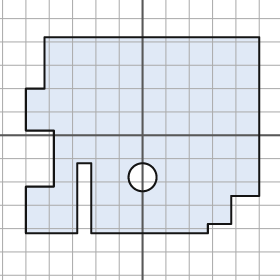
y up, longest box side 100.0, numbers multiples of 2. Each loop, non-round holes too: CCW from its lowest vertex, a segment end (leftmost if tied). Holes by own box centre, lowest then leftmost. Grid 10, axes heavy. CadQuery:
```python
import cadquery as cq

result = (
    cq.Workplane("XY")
    .moveTo(-50.0, -42.0)
    .lineTo(-28.0, -42.0)
    .lineTo(-28.0, -12.0)
    .lineTo(-22.0, -12.0)
    .lineTo(-22.0, -42.0)
    .lineTo(28.0, -42.0)
    .lineTo(28.0, -38.0)
    .lineTo(38.0, -38.0)
    .lineTo(38.0, -26.0)
    .lineTo(50.0, -26.0)
    .lineTo(50.0, 42.0)
    .lineTo(-42.0, 42.0)
    .lineTo(-42.0, 20.0)
    .lineTo(-50.0, 20.0)
    .lineTo(-50.0, 2.0)
    .lineTo(-38.0, 2.0)
    .lineTo(-38.0, -22.0)
    .lineTo(-50.0, -22.0)
    .close()
    .moveTo(0.0, -18.0)
    .circle(6.0)
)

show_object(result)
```